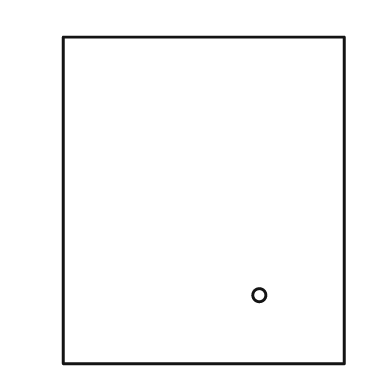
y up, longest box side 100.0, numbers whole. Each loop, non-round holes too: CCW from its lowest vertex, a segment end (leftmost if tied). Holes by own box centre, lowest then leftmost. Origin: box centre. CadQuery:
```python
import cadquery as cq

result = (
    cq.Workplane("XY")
    .moveTo(-43.0, -50.0)
    .lineTo(43.0, -50.0)
    .lineTo(43.0, 50.0)
    .lineTo(-43.0, 50.0)
    .close()
    .moveTo(17.0, -29.0)
    .circle(2.0)
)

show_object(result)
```